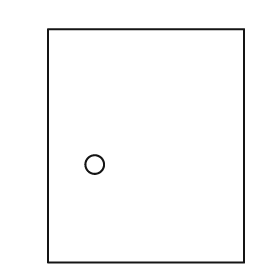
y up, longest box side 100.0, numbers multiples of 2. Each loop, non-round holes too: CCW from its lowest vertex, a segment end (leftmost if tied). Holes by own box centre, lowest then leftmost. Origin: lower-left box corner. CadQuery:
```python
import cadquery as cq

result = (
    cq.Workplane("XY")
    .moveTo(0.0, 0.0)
    .lineTo(84.0, 0.0)
    .lineTo(84.0, 100.0)
    .lineTo(0.0, 100.0)
    .close()
    .moveTo(20.0, 42.0)
    .circle(4.0)
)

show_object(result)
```